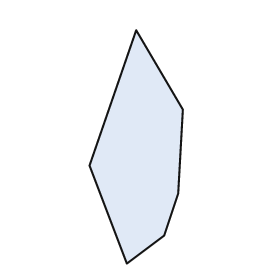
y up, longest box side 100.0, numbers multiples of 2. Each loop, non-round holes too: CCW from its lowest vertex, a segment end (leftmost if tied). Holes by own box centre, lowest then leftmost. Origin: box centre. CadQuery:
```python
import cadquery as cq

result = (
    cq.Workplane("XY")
    .moveTo(-4.0, -50.0)
    .lineTo(12.0, -38.0)
    .lineTo(18.0, -20.0)
    .lineTo(20.0, 16.0)
    .lineTo(0.0, 50.0)
    .lineTo(-20.0, -8.0)
    .close()
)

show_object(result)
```